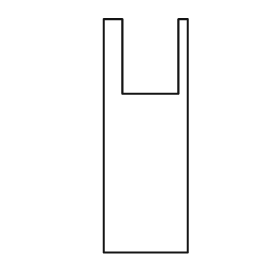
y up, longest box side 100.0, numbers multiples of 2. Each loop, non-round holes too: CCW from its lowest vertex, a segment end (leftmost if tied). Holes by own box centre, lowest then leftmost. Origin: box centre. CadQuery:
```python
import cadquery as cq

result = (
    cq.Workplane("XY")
    .moveTo(-18.0, -50.0)
    .lineTo(18.0, -50.0)
    .lineTo(18.0, 50.0)
    .lineTo(14.0, 50.0)
    .lineTo(14.0, 18.0)
    .lineTo(-10.0, 18.0)
    .lineTo(-10.0, 50.0)
    .lineTo(-18.0, 50.0)
    .close()
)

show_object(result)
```